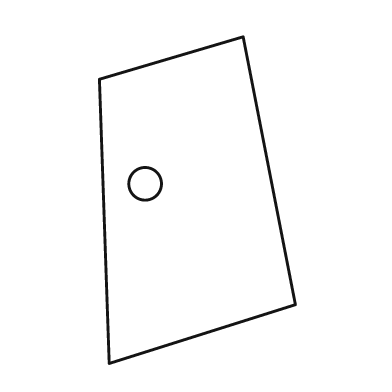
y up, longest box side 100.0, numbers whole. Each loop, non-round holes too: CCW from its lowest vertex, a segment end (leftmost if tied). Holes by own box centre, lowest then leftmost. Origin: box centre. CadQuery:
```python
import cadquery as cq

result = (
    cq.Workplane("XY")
    .moveTo(-27.0, -50.0)
    .lineTo(30.0, -32.0)
    .lineTo(14.0, 50.0)
    .lineTo(-30.0, 37.0)
    .close()
    .moveTo(-16.0, 5.0)
    .circle(5.0)
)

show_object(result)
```